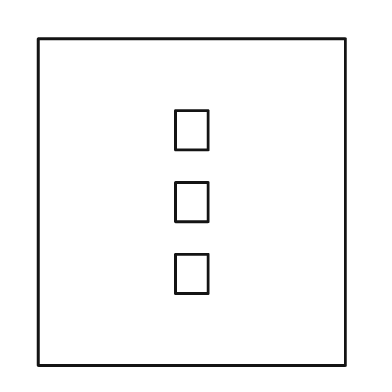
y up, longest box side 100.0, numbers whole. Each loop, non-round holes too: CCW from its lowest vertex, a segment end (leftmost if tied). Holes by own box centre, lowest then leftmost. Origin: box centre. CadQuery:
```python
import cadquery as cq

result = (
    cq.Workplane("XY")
    .moveTo(-47.0, -50.0)
    .lineTo(47.0, -50.0)
    .lineTo(47.0, 50.0)
    .lineTo(-47.0, 50.0)
    .close()
    .moveTo(-5.0, -28.0)
    .lineTo(5.0, -28.0)
    .lineTo(5.0, -16.0)
    .lineTo(-5.0, -16.0)
    .close()
    .moveTo(-5.0, -6.0)
    .lineTo(5.0, -6.0)
    .lineTo(5.0, 6.0)
    .lineTo(-5.0, 6.0)
    .close()
    .moveTo(-5.0, 16.0)
    .lineTo(5.0, 16.0)
    .lineTo(5.0, 28.0)
    .lineTo(-5.0, 28.0)
    .close()
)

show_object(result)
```